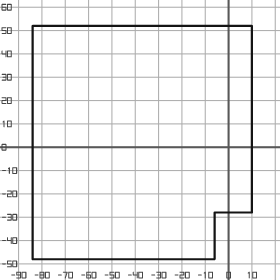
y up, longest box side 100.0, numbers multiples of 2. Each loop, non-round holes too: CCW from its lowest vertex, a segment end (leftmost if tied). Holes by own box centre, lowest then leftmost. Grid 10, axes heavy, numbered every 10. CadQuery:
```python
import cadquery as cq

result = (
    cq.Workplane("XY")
    .moveTo(-84.0, -48.0)
    .lineTo(-6.0, -48.0)
    .lineTo(-6.0, -28.0)
    .lineTo(10.0, -28.0)
    .lineTo(10.0, 52.0)
    .lineTo(-84.0, 52.0)
    .close()
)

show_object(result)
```